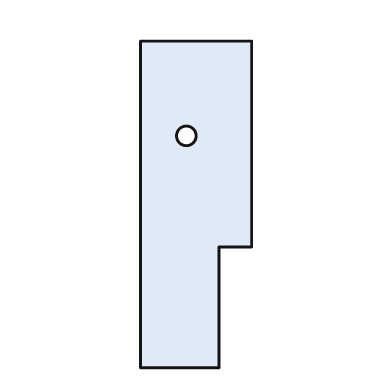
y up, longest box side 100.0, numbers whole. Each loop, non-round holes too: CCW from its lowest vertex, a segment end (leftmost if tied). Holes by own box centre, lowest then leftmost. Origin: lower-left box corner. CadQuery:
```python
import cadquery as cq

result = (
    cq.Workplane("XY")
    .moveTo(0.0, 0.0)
    .lineTo(24.0, 0.0)
    .lineTo(24.0, 37.0)
    .lineTo(34.0, 37.0)
    .lineTo(34.0, 100.0)
    .lineTo(0.0, 100.0)
    .close()
    .moveTo(14.0, 71.0)
    .circle(3.0)
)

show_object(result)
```